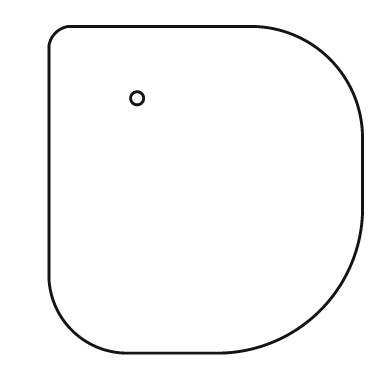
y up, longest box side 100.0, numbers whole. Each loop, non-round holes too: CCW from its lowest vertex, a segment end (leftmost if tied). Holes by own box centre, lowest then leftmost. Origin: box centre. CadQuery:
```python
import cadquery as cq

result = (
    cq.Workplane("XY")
    .moveTo(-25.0, -50.0)
    .lineTo(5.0, -50.0)
    .threePointArc((35.0, -37.0), (48.0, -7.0))
    .lineTo(48.0, 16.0)
    .threePointArc((38.0, 40.0), (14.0, 50.0))
    .lineTo(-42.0, 50.0)
    .threePointArc((-46.0, 48.0), (-48.0, 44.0))
    .lineTo(-48.0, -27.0)
    .threePointArc((-41.0, -43.0), (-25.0, -50.0))
    .close()
    .moveTo(-21.0, 28.0)
    .circle(2.0)
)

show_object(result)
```